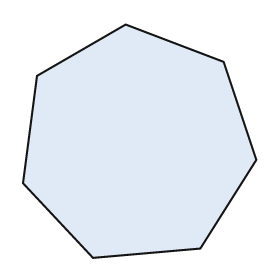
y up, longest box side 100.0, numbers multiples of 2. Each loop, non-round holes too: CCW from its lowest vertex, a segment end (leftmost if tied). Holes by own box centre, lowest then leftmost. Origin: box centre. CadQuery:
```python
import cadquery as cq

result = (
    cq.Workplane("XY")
    .moveTo(-20.0, -50.0)
    .lineTo(26.0, -46.0)
    .lineTo(50.0, -8.0)
    .lineTo(36.0, 34.0)
    .lineTo(-6.0, 50.0)
    .lineTo(-44.0, 28.0)
    .lineTo(-50.0, -18.0)
    .close()
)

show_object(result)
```